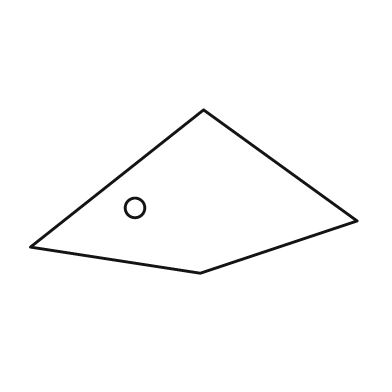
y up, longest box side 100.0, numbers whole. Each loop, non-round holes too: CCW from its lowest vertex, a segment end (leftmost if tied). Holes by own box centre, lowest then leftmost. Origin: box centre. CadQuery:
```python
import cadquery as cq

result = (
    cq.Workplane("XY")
    .moveTo(2.0, -25.0)
    .lineTo(50.0, -9.0)
    .lineTo(3.0, 25.0)
    .lineTo(-50.0, -17.0)
    .close()
    .moveTo(-18.0, -5.0)
    .circle(3.0)
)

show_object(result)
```